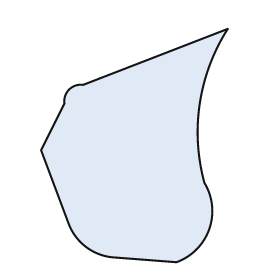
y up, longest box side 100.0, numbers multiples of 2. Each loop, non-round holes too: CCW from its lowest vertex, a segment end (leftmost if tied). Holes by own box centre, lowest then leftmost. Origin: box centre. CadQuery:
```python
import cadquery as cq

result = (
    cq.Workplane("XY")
    .moveTo(18.0, -50.0)
    .threePointArc((32.0, -36.0), (30.0, -16.0))
    .threePointArc((28.0, 18.0), (40.0, 50.0))
    .lineTo(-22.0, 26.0)
    .threePointArc((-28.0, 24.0), (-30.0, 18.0))
    .lineTo(-40.0, -2.0)
    .lineTo(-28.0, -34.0)
    .threePointArc((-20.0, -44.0), (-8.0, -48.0))
    .close()
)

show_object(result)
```